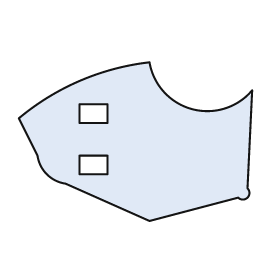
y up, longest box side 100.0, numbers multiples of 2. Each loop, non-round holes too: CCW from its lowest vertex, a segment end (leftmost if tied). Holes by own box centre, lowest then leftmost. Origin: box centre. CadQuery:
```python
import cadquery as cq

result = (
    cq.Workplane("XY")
    .moveTo(6.0, -34.0)
    .lineTo(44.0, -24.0)
    .threePointArc((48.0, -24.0), (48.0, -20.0))
    .lineTo(50.0, 22.0)
    .threePointArc((24.0, 14.0), (6.0, 34.0))
    .threePointArc((-24.0, 26.0), (-50.0, 10.0))
    .lineTo(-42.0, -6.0)
    .threePointArc((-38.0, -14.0), (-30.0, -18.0))
    .close()
    .moveTo(-24.0, -14.0)
    .lineTo(-12.0, -14.0)
    .lineTo(-12.0, -6.0)
    .lineTo(-24.0, -6.0)
    .close()
    .moveTo(-24.0, 8.0)
    .lineTo(-12.0, 8.0)
    .lineTo(-12.0, 16.0)
    .lineTo(-24.0, 16.0)
    .close()
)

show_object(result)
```